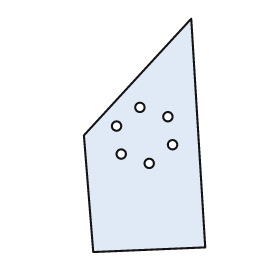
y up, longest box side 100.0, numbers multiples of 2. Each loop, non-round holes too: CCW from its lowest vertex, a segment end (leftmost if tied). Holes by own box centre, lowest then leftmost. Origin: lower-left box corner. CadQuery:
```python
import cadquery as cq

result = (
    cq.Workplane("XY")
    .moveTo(4.0, 0.0)
    .lineTo(52.0, 2.0)
    .lineTo(46.0, 100.0)
    .lineTo(0.0, 50.0)
    .close()
    .moveTo(28.0, 38.0)
    .circle(2.0)
    .moveTo(16.0, 42.0)
    .circle(2.0)
    .moveTo(38.0, 46.0)
    .circle(2.0)
    .moveTo(14.0, 54.0)
    .circle(2.0)
    .moveTo(36.0, 58.0)
    .circle(2.0)
    .moveTo(24.0, 62.0)
    .circle(2.0)
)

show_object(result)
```